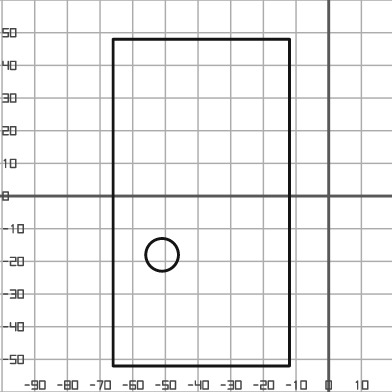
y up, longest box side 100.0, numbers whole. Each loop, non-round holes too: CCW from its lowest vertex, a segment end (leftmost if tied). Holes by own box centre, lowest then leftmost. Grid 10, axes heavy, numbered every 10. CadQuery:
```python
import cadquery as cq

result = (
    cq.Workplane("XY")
    .moveTo(-66.0, -52.0)
    .lineTo(-12.0, -52.0)
    .lineTo(-12.0, 48.0)
    .lineTo(-66.0, 48.0)
    .close()
    .moveTo(-51.0, -18.0)
    .circle(5.0)
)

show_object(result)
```